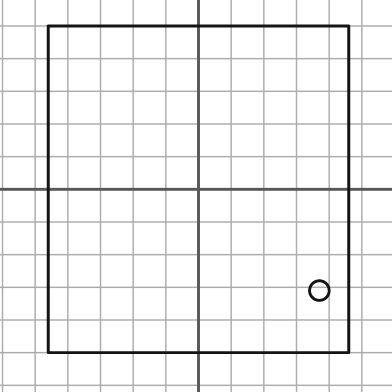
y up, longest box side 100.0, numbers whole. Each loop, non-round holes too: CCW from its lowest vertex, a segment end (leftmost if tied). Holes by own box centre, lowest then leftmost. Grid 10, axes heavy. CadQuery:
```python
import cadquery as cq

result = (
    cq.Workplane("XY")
    .moveTo(-46.0, -50.0)
    .lineTo(46.0, -50.0)
    .lineTo(46.0, 50.0)
    .lineTo(-46.0, 50.0)
    .close()
    .moveTo(37.0, -31.0)
    .circle(3.0)
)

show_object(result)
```